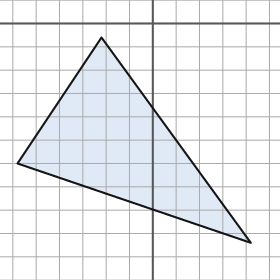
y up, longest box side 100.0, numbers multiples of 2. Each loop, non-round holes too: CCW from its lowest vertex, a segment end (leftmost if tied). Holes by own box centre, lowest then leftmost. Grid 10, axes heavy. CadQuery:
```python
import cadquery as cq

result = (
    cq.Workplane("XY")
    .moveTo(42.0, -94.0)
    .lineTo(-22.0, -6.0)
    .lineTo(-58.0, -60.0)
    .close()
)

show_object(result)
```